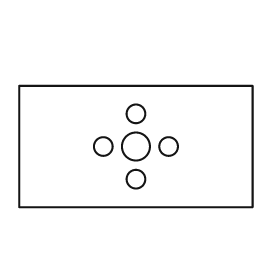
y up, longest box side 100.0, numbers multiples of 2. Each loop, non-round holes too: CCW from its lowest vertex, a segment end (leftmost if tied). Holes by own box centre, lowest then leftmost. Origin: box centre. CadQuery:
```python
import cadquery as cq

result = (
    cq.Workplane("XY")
    .moveTo(-50.0, -26.0)
    .lineTo(50.0, -26.0)
    .lineTo(50.0, 26.0)
    .lineTo(-50.0, 26.0)
    .close()
    .moveTo(0.0, -14.0)
    .circle(4.0)
    .moveTo(-14.0, 0.0)
    .circle(4.0)
    .moveTo(0.0, 0.0)
    .circle(6.0)
    .moveTo(14.0, 0.0)
    .circle(4.0)
    .moveTo(0.0, 14.0)
    .circle(4.0)
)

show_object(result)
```